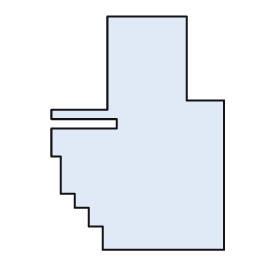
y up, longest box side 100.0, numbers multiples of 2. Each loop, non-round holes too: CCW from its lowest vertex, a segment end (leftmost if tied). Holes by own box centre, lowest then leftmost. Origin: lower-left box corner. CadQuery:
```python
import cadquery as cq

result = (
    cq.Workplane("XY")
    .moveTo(22.0, 0.0)
    .lineTo(74.0, 0.0)
    .lineTo(74.0, 64.0)
    .lineTo(58.0, 64.0)
    .lineTo(58.0, 100.0)
    .lineTo(24.0, 100.0)
    .lineTo(24.0, 60.0)
    .lineTo(0.0, 60.0)
    .lineTo(0.0, 56.0)
    .lineTo(28.0, 56.0)
    .lineTo(28.0, 52.0)
    .lineTo(0.0, 52.0)
    .lineTo(0.0, 40.0)
    .lineTo(4.0, 40.0)
    .lineTo(4.0, 24.0)
    .lineTo(10.0, 24.0)
    .lineTo(10.0, 18.0)
    .lineTo(16.0, 18.0)
    .lineTo(16.0, 10.0)
    .lineTo(22.0, 10.0)
    .close()
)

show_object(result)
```